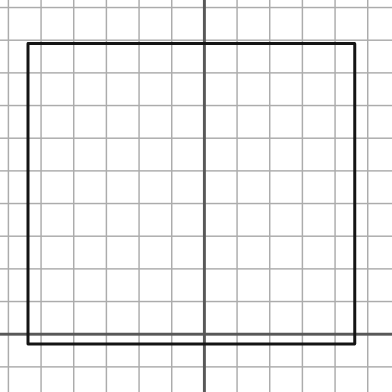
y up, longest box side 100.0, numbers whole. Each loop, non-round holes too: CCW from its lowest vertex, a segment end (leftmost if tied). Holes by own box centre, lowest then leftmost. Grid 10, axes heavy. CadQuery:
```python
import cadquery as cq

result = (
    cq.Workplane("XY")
    .moveTo(-54.0, -3.0)
    .lineTo(46.0, -3.0)
    .lineTo(46.0, 89.0)
    .lineTo(-54.0, 89.0)
    .close()
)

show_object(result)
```